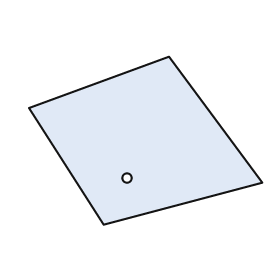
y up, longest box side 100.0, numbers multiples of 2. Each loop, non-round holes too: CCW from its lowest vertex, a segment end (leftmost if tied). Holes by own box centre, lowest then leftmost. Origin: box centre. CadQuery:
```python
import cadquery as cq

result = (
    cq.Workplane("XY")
    .moveTo(-18.0, -36.0)
    .lineTo(50.0, -18.0)
    .lineTo(10.0, 36.0)
    .lineTo(-50.0, 14.0)
    .close()
    .moveTo(-8.0, -16.0)
    .circle(2.0)
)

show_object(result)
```